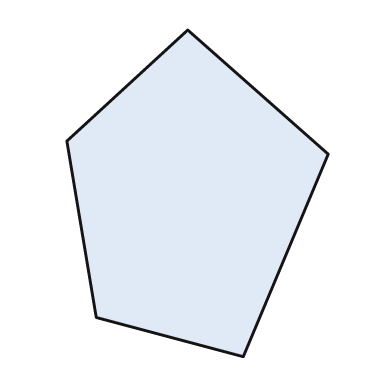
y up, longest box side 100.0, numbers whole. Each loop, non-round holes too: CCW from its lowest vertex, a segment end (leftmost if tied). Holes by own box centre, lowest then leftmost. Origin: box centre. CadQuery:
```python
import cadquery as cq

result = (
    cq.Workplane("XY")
    .moveTo(14.0, -50.0)
    .lineTo(40.0, 12.0)
    .lineTo(-3.0, 50.0)
    .lineTo(-40.0, 16.0)
    .lineTo(-31.0, -38.0)
    .close()
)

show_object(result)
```